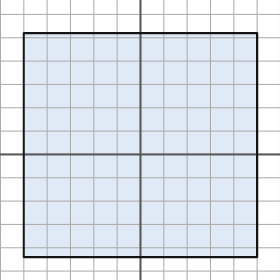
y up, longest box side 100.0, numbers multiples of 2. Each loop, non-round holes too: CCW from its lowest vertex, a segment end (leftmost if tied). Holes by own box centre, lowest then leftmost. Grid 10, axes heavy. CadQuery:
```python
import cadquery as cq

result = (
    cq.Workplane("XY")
    .moveTo(-50.0, -44.0)
    .lineTo(50.0, -44.0)
    .lineTo(50.0, 52.0)
    .lineTo(-50.0, 52.0)
    .close()
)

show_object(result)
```